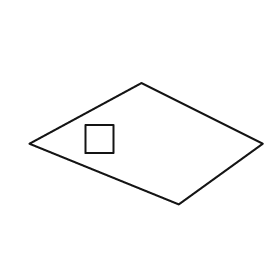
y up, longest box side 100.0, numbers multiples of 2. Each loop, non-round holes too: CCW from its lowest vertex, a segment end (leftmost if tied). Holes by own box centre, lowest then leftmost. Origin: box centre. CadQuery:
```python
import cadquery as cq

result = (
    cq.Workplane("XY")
    .moveTo(14.0, -26.0)
    .lineTo(50.0, 0.0)
    .lineTo(-2.0, 26.0)
    .lineTo(-50.0, 0.0)
    .close()
    .moveTo(-26.0, -4.0)
    .lineTo(-14.0, -4.0)
    .lineTo(-14.0, 8.0)
    .lineTo(-26.0, 8.0)
    .close()
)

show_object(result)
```